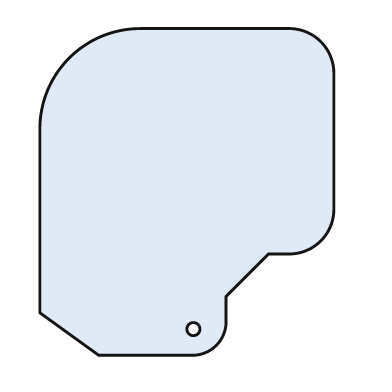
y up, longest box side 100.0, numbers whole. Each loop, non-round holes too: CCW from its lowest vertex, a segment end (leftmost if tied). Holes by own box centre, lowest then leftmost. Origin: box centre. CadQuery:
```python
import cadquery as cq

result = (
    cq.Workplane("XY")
    .moveTo(-27.0, -50.0)
    .lineTo(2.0, -50.0)
    .threePointArc((9.0, -47.0), (12.0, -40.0))
    .lineTo(12.0, -32.0)
    .lineTo(25.0, -19.0)
    .lineTo(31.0, -19.0)
    .threePointArc((41.0, -15.0), (45.0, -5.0))
    .lineTo(45.0, 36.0)
    .threePointArc((41.0, 46.0), (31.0, 50.0))
    .lineTo(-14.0, 50.0)
    .threePointArc((-36.0, 41.0), (-45.0, 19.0))
    .lineTo(-45.0, -37.0)
    .close()
    .moveTo(2.0, -42.0)
    .circle(2.0)
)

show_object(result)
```